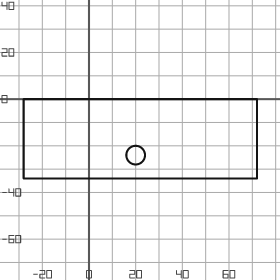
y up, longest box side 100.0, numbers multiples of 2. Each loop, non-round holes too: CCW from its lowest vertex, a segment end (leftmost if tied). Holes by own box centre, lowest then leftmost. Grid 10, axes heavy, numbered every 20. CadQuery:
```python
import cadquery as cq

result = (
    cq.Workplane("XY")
    .moveTo(-28.0, -34.0)
    .lineTo(72.0, -34.0)
    .lineTo(72.0, 0.0)
    .lineTo(-28.0, 0.0)
    .close()
    .moveTo(20.0, -24.0)
    .circle(4.0)
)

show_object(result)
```